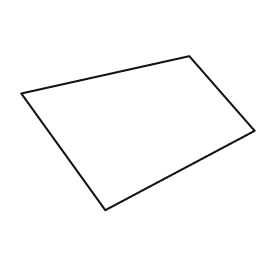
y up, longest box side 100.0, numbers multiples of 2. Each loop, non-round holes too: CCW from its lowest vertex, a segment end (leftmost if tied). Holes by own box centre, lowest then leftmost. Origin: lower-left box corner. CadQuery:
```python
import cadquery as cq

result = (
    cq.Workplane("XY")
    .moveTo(36.0, 0.0)
    .lineTo(100.0, 34.0)
    .lineTo(72.0, 66.0)
    .lineTo(0.0, 50.0)
    .close()
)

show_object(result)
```